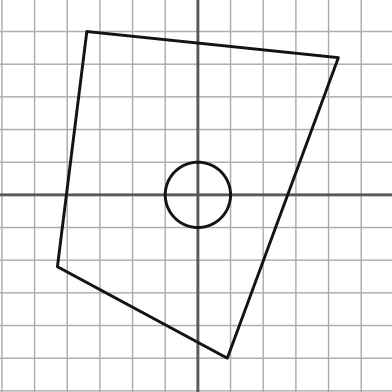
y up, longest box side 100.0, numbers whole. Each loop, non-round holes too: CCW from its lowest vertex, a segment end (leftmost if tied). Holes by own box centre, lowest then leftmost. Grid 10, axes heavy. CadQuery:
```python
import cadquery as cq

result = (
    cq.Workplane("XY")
    .moveTo(9.0, -50.0)
    .lineTo(43.0, 42.0)
    .lineTo(-34.0, 50.0)
    .lineTo(-43.0, -22.0)
    .close()
    .moveTo(0.0, 0.0)
    .circle(10.0)
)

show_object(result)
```